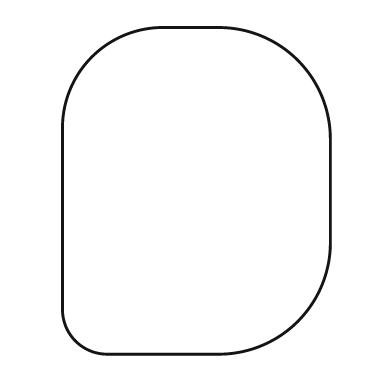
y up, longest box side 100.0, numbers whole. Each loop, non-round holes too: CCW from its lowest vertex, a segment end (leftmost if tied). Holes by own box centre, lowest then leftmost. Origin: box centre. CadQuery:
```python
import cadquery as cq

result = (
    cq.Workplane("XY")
    .moveTo(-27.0, -50.0)
    .lineTo(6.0, -50.0)
    .threePointArc((31.0, -40.0), (41.0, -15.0))
    .lineTo(41.0, 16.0)
    .threePointArc((31.0, 40.0), (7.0, 50.0))
    .lineTo(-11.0, 50.0)
    .threePointArc((-32.0, 41.0), (-41.0, 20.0))
    .lineTo(-41.0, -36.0)
    .threePointArc((-37.0, -46.0), (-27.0, -50.0))
    .close()
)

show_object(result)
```